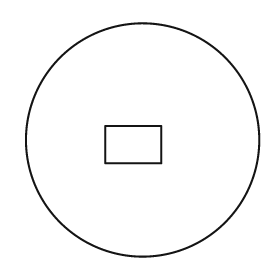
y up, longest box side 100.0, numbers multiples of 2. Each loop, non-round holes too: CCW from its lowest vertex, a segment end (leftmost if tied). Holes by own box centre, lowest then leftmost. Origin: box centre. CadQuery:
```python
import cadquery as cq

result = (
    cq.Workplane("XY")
    .moveTo(0.0, 0.0)
    .circle(50.0)
    .moveTo(-16.0, -10.0)
    .lineTo(8.0, -10.0)
    .lineTo(8.0, 6.0)
    .lineTo(-16.0, 6.0)
    .close()
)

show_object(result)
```